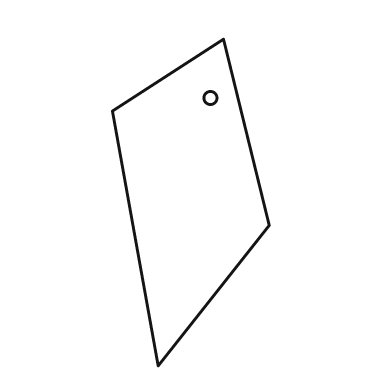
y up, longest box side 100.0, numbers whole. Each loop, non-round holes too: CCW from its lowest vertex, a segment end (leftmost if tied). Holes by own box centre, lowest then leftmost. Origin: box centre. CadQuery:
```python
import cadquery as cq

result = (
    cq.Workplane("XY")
    .moveTo(-10.0, -50.0)
    .lineTo(24.0, -7.0)
    .lineTo(10.0, 50.0)
    .lineTo(-24.0, 28.0)
    .close()
    .moveTo(6.0, 32.0)
    .circle(2.0)
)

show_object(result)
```